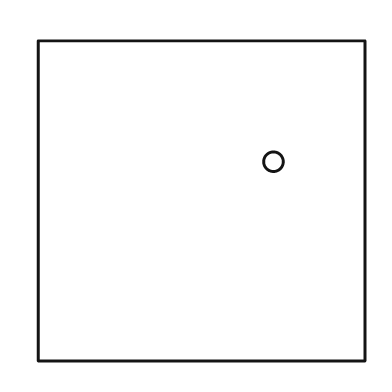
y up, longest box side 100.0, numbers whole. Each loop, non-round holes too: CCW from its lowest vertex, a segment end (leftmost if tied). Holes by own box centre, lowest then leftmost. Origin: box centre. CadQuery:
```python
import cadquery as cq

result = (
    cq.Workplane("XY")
    .moveTo(-50.0, -49.0)
    .lineTo(50.0, -49.0)
    .lineTo(50.0, 49.0)
    .lineTo(-50.0, 49.0)
    .close()
    .moveTo(22.0, 12.0)
    .circle(3.0)
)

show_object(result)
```